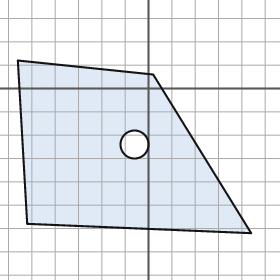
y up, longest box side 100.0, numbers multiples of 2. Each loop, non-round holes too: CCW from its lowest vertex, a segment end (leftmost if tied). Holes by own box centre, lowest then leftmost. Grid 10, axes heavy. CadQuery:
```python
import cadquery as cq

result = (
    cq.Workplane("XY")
    .moveTo(44.0, -62.0)
    .lineTo(2.0, 6.0)
    .lineTo(-56.0, 12.0)
    .lineTo(-52.0, -58.0)
    .close()
    .moveTo(-6.0, -24.0)
    .circle(6.0)
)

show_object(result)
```